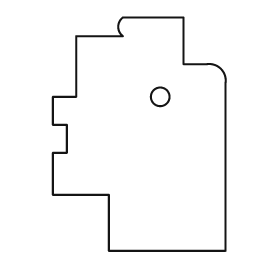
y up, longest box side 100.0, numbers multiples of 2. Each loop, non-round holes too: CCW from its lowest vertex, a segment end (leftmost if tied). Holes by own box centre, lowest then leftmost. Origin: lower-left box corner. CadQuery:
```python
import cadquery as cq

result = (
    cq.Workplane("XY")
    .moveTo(24.0, 0.0)
    .lineTo(74.0, 0.0)
    .lineTo(74.0, 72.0)
    .threePointArc((72.0, 78.0), (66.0, 80.0))
    .lineTo(56.0, 80.0)
    .lineTo(56.0, 100.0)
    .lineTo(30.0, 100.0)
    .threePointArc((28.0, 96.0), (30.0, 92.0))
    .lineTo(10.0, 92.0)
    .lineTo(10.0, 66.0)
    .lineTo(0.0, 66.0)
    .lineTo(0.0, 54.0)
    .lineTo(6.0, 54.0)
    .lineTo(6.0, 42.0)
    .lineTo(0.0, 42.0)
    .lineTo(0.0, 24.0)
    .lineTo(24.0, 24.0)
    .close()
    .moveTo(46.0, 66.0)
    .circle(4.0)
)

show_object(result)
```